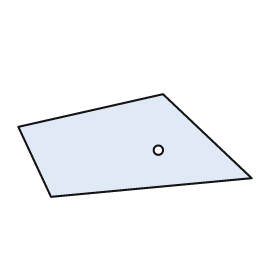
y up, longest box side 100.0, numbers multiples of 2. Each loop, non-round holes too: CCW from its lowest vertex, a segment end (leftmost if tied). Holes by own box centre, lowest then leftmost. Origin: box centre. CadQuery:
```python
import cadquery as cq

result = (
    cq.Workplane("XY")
    .moveTo(-36.0, -22.0)
    .lineTo(50.0, -14.0)
    .lineTo(12.0, 22.0)
    .lineTo(-50.0, 8.0)
    .close()
    .moveTo(10.0, -2.0)
    .circle(2.0)
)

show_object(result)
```